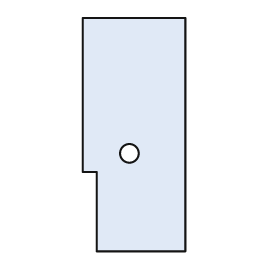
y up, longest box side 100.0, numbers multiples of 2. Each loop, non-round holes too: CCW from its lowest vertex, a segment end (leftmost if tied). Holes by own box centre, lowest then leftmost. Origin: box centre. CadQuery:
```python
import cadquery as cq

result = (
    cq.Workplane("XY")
    .moveTo(-16.0, -50.0)
    .lineTo(22.0, -50.0)
    .lineTo(22.0, 50.0)
    .lineTo(-22.0, 50.0)
    .lineTo(-22.0, -16.0)
    .lineTo(-16.0, -16.0)
    .close()
    .moveTo(-2.0, -8.0)
    .circle(4.0)
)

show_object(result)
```